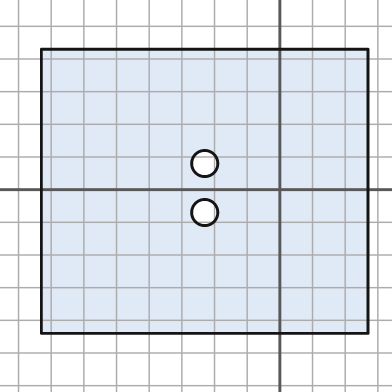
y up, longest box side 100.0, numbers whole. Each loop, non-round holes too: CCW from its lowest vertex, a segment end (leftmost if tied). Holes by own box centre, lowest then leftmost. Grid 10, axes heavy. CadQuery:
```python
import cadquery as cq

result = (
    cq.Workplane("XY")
    .moveTo(-73.0, -44.0)
    .lineTo(27.0, -44.0)
    .lineTo(27.0, 43.0)
    .lineTo(-73.0, 43.0)
    .close()
    .moveTo(-23.0, -7.0)
    .circle(4.0)
    .moveTo(-23.0, 8.0)
    .circle(4.0)
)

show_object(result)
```